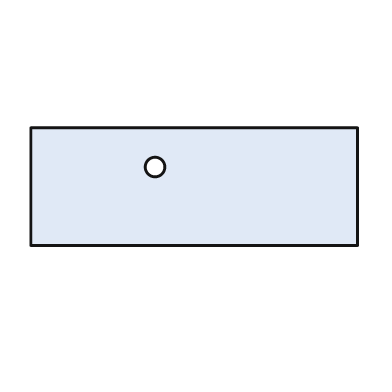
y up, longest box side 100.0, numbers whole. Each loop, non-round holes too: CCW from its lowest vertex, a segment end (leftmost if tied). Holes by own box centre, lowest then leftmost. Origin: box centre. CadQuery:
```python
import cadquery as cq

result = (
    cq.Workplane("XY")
    .moveTo(-50.0, -18.0)
    .lineTo(50.0, -18.0)
    .lineTo(50.0, 18.0)
    .lineTo(-50.0, 18.0)
    .close()
    .moveTo(-12.0, 6.0)
    .circle(3.0)
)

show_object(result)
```